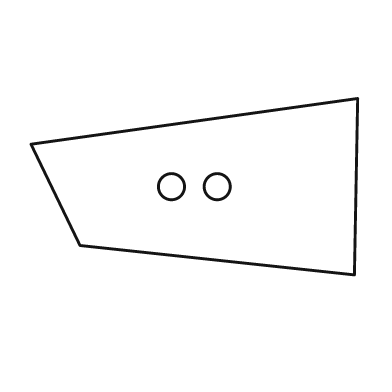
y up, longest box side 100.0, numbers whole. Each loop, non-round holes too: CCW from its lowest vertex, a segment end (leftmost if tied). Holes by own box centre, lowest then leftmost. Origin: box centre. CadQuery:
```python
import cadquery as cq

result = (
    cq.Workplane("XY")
    .moveTo(49.0, -27.0)
    .lineTo(50.0, 27.0)
    .lineTo(-50.0, 13.0)
    .lineTo(-35.0, -18.0)
    .close()
    .moveTo(-7.0, 0.0)
    .circle(4.0)
    .moveTo(7.0, 0.0)
    .circle(4.0)
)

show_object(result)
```